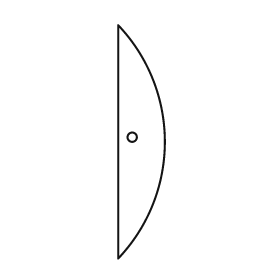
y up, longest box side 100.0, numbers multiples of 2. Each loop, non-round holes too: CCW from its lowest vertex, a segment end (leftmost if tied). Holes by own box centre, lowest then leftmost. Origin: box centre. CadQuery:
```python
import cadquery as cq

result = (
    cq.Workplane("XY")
    .moveTo(-10.0, -50.0)
    .threePointArc((10.0, 0.0), (-10.0, 50.0))
    .close()
    .moveTo(-4.0, 2.0)
    .circle(2.0)
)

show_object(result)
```